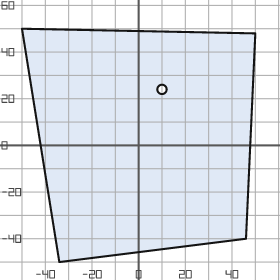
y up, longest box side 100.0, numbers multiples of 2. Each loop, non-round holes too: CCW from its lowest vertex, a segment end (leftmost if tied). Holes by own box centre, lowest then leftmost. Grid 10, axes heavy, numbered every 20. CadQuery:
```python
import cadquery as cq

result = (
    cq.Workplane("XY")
    .moveTo(-34.0, -50.0)
    .lineTo(46.0, -40.0)
    .lineTo(50.0, 48.0)
    .lineTo(-50.0, 50.0)
    .close()
    .moveTo(10.0, 24.0)
    .circle(2.0)
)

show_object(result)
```